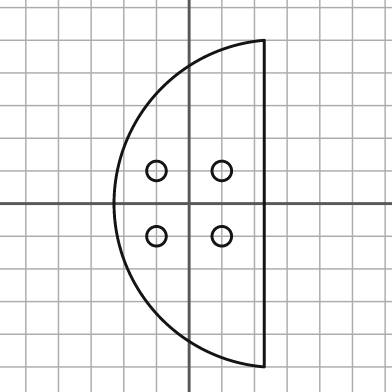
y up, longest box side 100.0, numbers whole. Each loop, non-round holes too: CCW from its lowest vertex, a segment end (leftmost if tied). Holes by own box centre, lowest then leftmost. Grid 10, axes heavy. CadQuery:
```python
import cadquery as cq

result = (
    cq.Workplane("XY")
    .moveTo(23.0, -50.0)
    .lineTo(23.0, 50.0)
    .threePointArc((-23.0, 0.0), (23.0, -50.0))
    .close()
    .moveTo(-10.0, -10.0)
    .circle(3.0)
    .moveTo(10.0, -10.0)
    .circle(3.0)
    .moveTo(-10.0, 10.0)
    .circle(3.0)
    .moveTo(10.0, 10.0)
    .circle(3.0)
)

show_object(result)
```